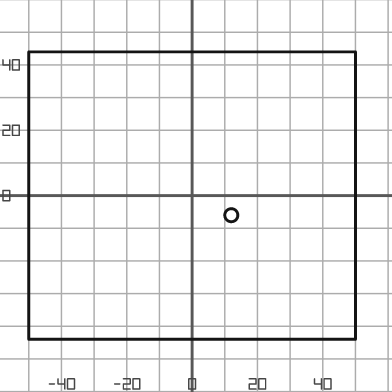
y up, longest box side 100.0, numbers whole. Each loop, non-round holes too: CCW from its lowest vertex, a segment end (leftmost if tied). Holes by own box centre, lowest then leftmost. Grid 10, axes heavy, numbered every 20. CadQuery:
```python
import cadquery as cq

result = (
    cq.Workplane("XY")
    .moveTo(-50.0, -44.0)
    .lineTo(50.0, -44.0)
    .lineTo(50.0, 44.0)
    .lineTo(-50.0, 44.0)
    .close()
    .moveTo(12.0, -6.0)
    .circle(2.0)
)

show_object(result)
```